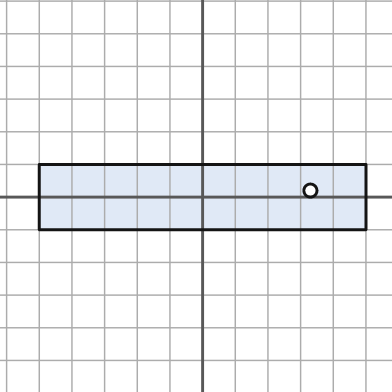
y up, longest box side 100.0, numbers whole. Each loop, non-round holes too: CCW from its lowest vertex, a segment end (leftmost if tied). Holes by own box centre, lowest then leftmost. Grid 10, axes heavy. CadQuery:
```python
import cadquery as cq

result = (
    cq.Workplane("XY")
    .moveTo(-50.0, -10.0)
    .lineTo(50.0, -10.0)
    .lineTo(50.0, 10.0)
    .lineTo(-50.0, 10.0)
    .close()
    .moveTo(33.0, 2.0)
    .circle(2.0)
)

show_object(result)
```